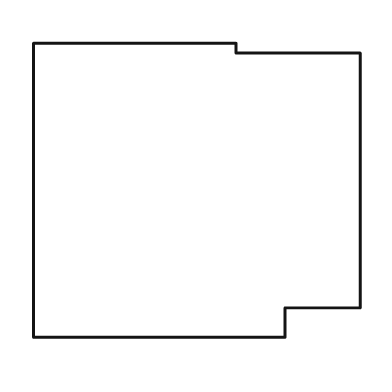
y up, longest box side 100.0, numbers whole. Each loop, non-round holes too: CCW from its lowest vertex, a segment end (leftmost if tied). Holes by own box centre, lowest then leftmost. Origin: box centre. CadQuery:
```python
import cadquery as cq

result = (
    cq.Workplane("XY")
    .moveTo(-50.0, -45.0)
    .lineTo(27.0, -45.0)
    .lineTo(27.0, -36.0)
    .lineTo(50.0, -36.0)
    .lineTo(50.0, 42.0)
    .lineTo(12.0, 42.0)
    .lineTo(12.0, 45.0)
    .lineTo(-50.0, 45.0)
    .close()
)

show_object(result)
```